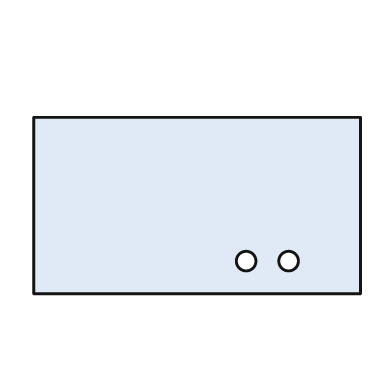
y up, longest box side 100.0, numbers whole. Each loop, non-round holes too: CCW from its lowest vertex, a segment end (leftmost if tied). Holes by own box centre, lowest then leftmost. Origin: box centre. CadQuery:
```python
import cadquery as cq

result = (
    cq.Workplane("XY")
    .moveTo(-50.0, -27.0)
    .lineTo(50.0, -27.0)
    .lineTo(50.0, 27.0)
    .lineTo(-50.0, 27.0)
    .close()
    .moveTo(15.0, -17.0)
    .circle(3.0)
    .moveTo(28.0, -17.0)
    .circle(3.0)
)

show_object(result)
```